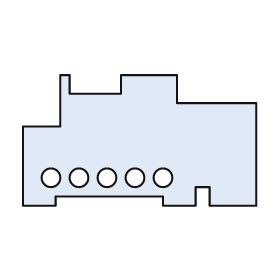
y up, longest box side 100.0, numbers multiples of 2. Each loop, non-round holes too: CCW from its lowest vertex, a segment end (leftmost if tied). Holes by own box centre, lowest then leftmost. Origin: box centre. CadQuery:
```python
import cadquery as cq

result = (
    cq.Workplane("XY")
    .moveTo(-50.0, -28.0)
    .lineTo(-36.0, -28.0)
    .lineTo(-36.0, -24.0)
    .lineTo(10.0, -24.0)
    .lineTo(10.0, -28.0)
    .lineTo(24.0, -28.0)
    .lineTo(24.0, -20.0)
    .lineTo(30.0, -20.0)
    .lineTo(30.0, -28.0)
    .lineTo(50.0, -28.0)
    .lineTo(50.0, 16.0)
    .lineTo(16.0, 16.0)
    .lineTo(16.0, 28.0)
    .lineTo(-8.0, 28.0)
    .lineTo(-8.0, 20.0)
    .lineTo(-30.0, 20.0)
    .lineTo(-30.0, 28.0)
    .lineTo(-34.0, 28.0)
    .lineTo(-34.0, 6.0)
    .lineTo(-50.0, 6.0)
    .close()
    .moveTo(-38.0, -16.0)
    .circle(4.0)
    .moveTo(-26.0, -16.0)
    .circle(4.0)
    .moveTo(-14.0, -16.0)
    .circle(4.0)
    .moveTo(-2.0, -16.0)
    .circle(4.0)
    .moveTo(10.0, -16.0)
    .circle(4.0)
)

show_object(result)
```